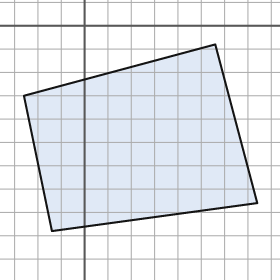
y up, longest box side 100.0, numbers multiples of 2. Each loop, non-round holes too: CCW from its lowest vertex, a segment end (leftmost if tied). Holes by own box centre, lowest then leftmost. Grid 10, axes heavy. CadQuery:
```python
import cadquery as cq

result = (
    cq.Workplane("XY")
    .moveTo(-14.0, -88.0)
    .lineTo(74.0, -76.0)
    .lineTo(56.0, -8.0)
    .lineTo(-26.0, -30.0)
    .close()
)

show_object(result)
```